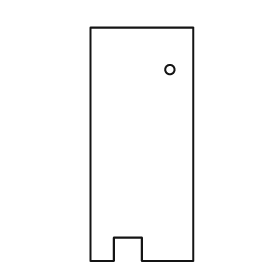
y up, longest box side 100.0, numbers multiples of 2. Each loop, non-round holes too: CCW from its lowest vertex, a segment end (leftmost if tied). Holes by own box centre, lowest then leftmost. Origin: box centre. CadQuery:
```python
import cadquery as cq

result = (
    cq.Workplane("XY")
    .moveTo(-22.0, -50.0)
    .lineTo(-12.0, -50.0)
    .lineTo(-12.0, -40.0)
    .lineTo(0.0, -40.0)
    .lineTo(0.0, -50.0)
    .lineTo(22.0, -50.0)
    .lineTo(22.0, 50.0)
    .lineTo(-22.0, 50.0)
    .close()
    .moveTo(12.0, 32.0)
    .circle(2.0)
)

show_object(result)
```